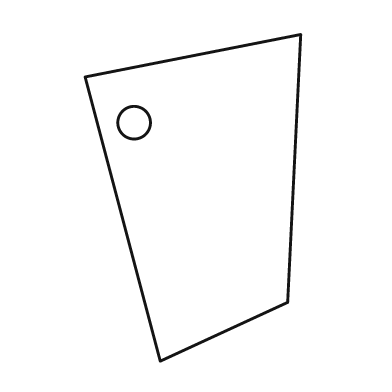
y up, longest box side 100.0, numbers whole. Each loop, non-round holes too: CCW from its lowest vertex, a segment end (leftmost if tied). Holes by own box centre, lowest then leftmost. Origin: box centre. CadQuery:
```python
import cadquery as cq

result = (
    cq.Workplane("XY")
    .moveTo(-10.0, -50.0)
    .lineTo(29.0, -32.0)
    .lineTo(33.0, 50.0)
    .lineTo(-33.0, 37.0)
    .close()
    .moveTo(-18.0, 23.0)
    .circle(5.0)
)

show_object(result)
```